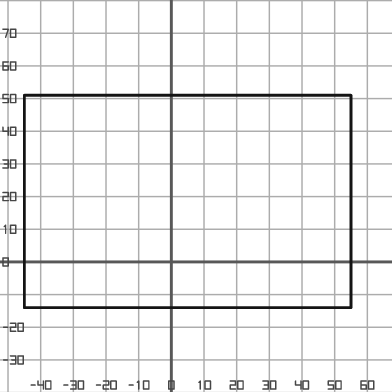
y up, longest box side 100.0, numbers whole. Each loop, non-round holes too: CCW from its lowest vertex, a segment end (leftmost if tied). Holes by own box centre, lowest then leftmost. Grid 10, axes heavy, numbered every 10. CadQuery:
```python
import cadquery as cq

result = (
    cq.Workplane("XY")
    .moveTo(-45.0, -14.0)
    .lineTo(55.0, -14.0)
    .lineTo(55.0, 51.0)
    .lineTo(-45.0, 51.0)
    .close()
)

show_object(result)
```